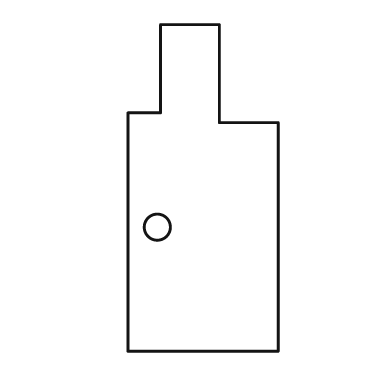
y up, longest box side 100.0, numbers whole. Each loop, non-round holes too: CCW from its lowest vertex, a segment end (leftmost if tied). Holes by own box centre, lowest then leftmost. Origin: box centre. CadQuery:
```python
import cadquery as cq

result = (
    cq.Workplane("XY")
    .moveTo(-23.0, -50.0)
    .lineTo(23.0, -50.0)
    .lineTo(23.0, 20.0)
    .lineTo(5.0, 20.0)
    .lineTo(5.0, 50.0)
    .lineTo(-13.0, 50.0)
    .lineTo(-13.0, 23.0)
    .lineTo(-23.0, 23.0)
    .close()
    .moveTo(-14.0, -12.0)
    .circle(4.0)
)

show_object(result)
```